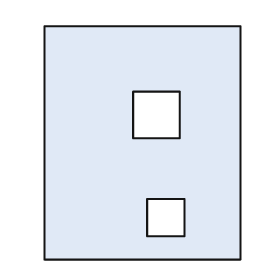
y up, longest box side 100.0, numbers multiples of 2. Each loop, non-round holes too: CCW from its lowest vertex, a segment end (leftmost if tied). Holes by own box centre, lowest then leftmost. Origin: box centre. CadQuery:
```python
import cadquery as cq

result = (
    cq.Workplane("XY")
    .moveTo(-42.0, -50.0)
    .lineTo(42.0, -50.0)
    .lineTo(42.0, 50.0)
    .lineTo(-42.0, 50.0)
    .close()
    .moveTo(2.0, -40.0)
    .lineTo(18.0, -40.0)
    .lineTo(18.0, -24.0)
    .lineTo(2.0, -24.0)
    .close()
    .moveTo(-4.0, 2.0)
    .lineTo(16.0, 2.0)
    .lineTo(16.0, 22.0)
    .lineTo(-4.0, 22.0)
    .close()
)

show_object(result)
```